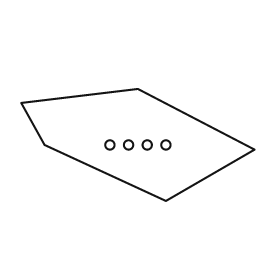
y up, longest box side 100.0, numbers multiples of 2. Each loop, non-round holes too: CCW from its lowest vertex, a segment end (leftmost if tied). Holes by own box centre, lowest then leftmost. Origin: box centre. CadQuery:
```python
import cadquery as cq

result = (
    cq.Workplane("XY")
    .moveTo(12.0, -24.0)
    .lineTo(50.0, -2.0)
    .lineTo(0.0, 24.0)
    .lineTo(-50.0, 18.0)
    .lineTo(-40.0, 0.0)
    .close()
    .moveTo(-12.0, 0.0)
    .circle(2.0)
    .moveTo(-4.0, 0.0)
    .circle(2.0)
    .moveTo(4.0, 0.0)
    .circle(2.0)
    .moveTo(12.0, 0.0)
    .circle(2.0)
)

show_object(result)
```